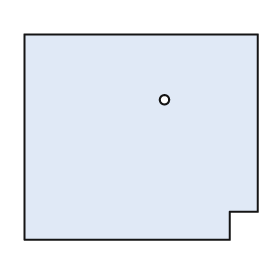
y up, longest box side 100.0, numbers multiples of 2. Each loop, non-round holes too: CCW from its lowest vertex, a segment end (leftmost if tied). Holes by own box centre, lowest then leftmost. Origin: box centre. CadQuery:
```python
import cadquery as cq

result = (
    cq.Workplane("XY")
    .moveTo(-50.0, -44.0)
    .lineTo(38.0, -44.0)
    .lineTo(38.0, -32.0)
    .lineTo(50.0, -32.0)
    .lineTo(50.0, 44.0)
    .lineTo(-50.0, 44.0)
    .close()
    .moveTo(10.0, 16.0)
    .circle(2.0)
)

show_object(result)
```